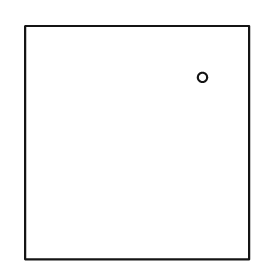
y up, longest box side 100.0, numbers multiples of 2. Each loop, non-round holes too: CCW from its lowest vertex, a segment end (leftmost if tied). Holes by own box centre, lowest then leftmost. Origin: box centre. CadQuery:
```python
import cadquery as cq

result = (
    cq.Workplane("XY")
    .moveTo(-48.0, -50.0)
    .lineTo(48.0, -50.0)
    .lineTo(48.0, 50.0)
    .lineTo(-48.0, 50.0)
    .close()
    .moveTo(28.0, 28.0)
    .circle(2.0)
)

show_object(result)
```